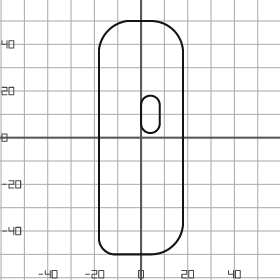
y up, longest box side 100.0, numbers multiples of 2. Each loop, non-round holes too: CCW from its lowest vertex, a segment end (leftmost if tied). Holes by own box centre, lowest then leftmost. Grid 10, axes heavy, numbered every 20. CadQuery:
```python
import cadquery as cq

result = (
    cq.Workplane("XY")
    .moveTo(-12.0, -50.0)
    .lineTo(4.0, -50.0)
    .threePointArc((14.0, -46.0), (18.0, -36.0))
    .lineTo(18.0, 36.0)
    .threePointArc((14.0, 46.0), (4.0, 50.0))
    .lineTo(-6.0, 50.0)
    .threePointArc((-14.0, 46.0), (-18.0, 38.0))
    .lineTo(-18.0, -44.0)
    .threePointArc((-16.0, -48.0), (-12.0, -50.0))
    .close()
    .moveTo(0.0, 6.0)
    .threePointArc((4.0, 2.0), (8.0, 6.0))
    .lineTo(8.0, 14.0)
    .threePointArc((4.0, 18.0), (0.0, 14.0))
    .close()
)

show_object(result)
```